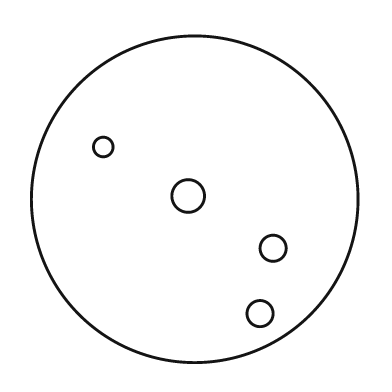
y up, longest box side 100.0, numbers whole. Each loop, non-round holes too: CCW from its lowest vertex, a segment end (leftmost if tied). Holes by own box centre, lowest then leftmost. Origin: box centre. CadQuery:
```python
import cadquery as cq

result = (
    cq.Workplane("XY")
    .moveTo(0.0, 0.0)
    .circle(50.0)
    .moveTo(20.0, -35.0)
    .circle(4.0)
    .moveTo(24.0, -15.0)
    .circle(4.0)
    .moveTo(-2.0, 1.0)
    .circle(5.0)
    .moveTo(-28.0, 16.0)
    .circle(3.0)
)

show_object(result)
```